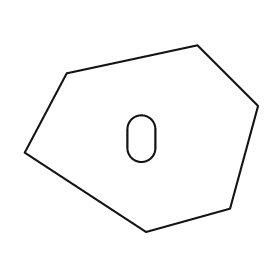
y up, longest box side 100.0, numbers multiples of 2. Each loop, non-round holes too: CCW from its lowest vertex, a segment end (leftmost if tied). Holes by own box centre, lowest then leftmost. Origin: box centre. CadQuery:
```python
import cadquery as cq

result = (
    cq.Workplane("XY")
    .moveTo(2.0, -40.0)
    .lineTo(38.0, -30.0)
    .lineTo(50.0, 14.0)
    .lineTo(24.0, 40.0)
    .lineTo(-32.0, 28.0)
    .lineTo(-50.0, -6.0)
    .close()
    .moveTo(-6.0, -4.0)
    .threePointArc((0.0, -10.0), (6.0, -4.0))
    .lineTo(6.0, 4.0)
    .threePointArc((0.0, 10.0), (-6.0, 4.0))
    .close()
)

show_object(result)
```